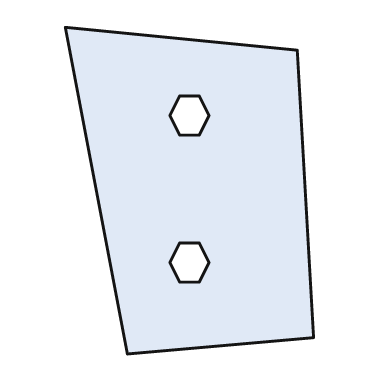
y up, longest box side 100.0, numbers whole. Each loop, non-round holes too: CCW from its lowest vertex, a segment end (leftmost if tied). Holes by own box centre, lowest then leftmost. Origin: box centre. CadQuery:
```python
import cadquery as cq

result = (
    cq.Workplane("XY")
    .moveTo(-19.0, -50.0)
    .lineTo(38.0, -45.0)
    .lineTo(33.0, 43.0)
    .lineTo(-38.0, 50.0)
    .close()
    .moveTo(-3.0, -28.0)
    .lineTo(3.0, -28.0)
    .lineTo(6.0, -22.0)
    .lineTo(3.0, -16.0)
    .lineTo(-3.0, -16.0)
    .lineTo(-6.0, -22.0)
    .close()
    .moveTo(-3.0, 17.0)
    .lineTo(3.0, 17.0)
    .lineTo(6.0, 23.0)
    .lineTo(3.0, 29.0)
    .lineTo(-3.0, 29.0)
    .lineTo(-6.0, 23.0)
    .close()
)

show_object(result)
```